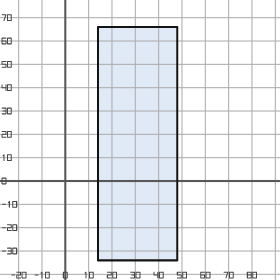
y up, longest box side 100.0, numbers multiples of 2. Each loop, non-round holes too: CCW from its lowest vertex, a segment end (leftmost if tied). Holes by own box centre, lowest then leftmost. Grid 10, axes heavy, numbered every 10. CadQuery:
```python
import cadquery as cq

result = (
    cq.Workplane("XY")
    .moveTo(14.0, -34.0)
    .lineTo(48.0, -34.0)
    .lineTo(48.0, 66.0)
    .lineTo(14.0, 66.0)
    .close()
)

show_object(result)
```